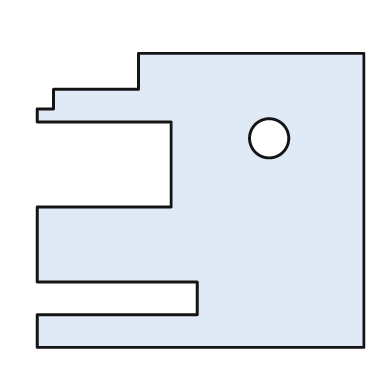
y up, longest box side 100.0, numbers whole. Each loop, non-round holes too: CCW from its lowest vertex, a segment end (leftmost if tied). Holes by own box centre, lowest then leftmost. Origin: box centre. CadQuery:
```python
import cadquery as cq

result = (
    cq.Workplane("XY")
    .moveTo(-50.0, -45.0)
    .lineTo(50.0, -45.0)
    .lineTo(50.0, 45.0)
    .lineTo(-19.0, 45.0)
    .lineTo(-19.0, 34.0)
    .lineTo(-45.0, 34.0)
    .lineTo(-45.0, 28.0)
    .lineTo(-50.0, 28.0)
    .lineTo(-50.0, 24.0)
    .lineTo(-9.0, 24.0)
    .lineTo(-9.0, -2.0)
    .lineTo(-50.0, -2.0)
    .lineTo(-50.0, -25.0)
    .lineTo(-1.0, -25.0)
    .lineTo(-1.0, -35.0)
    .lineTo(-50.0, -35.0)
    .close()
    .moveTo(21.0, 19.0)
    .circle(6.0)
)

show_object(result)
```